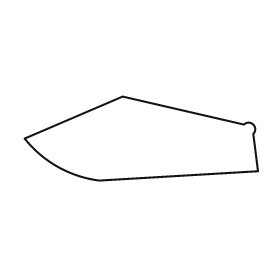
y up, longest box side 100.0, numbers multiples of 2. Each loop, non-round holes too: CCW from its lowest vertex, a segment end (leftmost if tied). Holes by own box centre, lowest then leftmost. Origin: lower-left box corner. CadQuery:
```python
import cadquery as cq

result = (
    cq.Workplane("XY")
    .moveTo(32.0, 0.0)
    .lineTo(100.0, 4.0)
    .lineTo(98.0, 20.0)
    .threePointArc((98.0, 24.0), (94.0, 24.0))
    .lineTo(42.0, 36.0)
    .lineTo(0.0, 18.0)
    .threePointArc((14.0, 6.0), (32.0, 0.0))
    .close()
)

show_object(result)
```